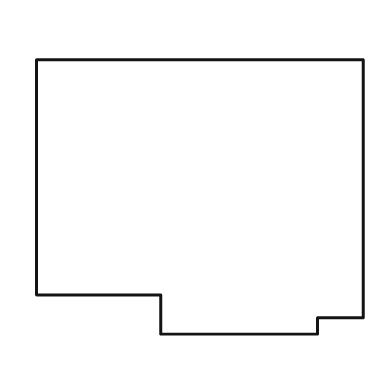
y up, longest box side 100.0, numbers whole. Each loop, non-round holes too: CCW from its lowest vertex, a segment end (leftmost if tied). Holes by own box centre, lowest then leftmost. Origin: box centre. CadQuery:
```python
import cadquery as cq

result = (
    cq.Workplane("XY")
    .moveTo(-12.0, -42.0)
    .lineTo(36.0, -42.0)
    .lineTo(36.0, -37.0)
    .lineTo(50.0, -37.0)
    .lineTo(50.0, 42.0)
    .lineTo(-50.0, 42.0)
    .lineTo(-50.0, -30.0)
    .lineTo(-12.0, -30.0)
    .close()
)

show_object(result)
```